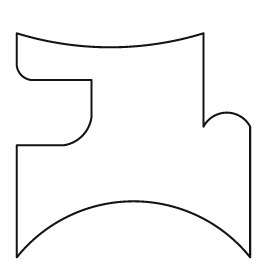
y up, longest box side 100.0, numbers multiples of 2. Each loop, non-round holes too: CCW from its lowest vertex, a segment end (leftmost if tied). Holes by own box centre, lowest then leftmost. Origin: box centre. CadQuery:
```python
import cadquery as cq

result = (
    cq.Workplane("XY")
    .moveTo(-50.0, -48.0)
    .threePointArc((0.0, -24.0), (50.0, -48.0))
    .lineTo(50.0, 8.0)
    .threePointArc((40.0, 14.0), (30.0, 8.0))
    .lineTo(30.0, 48.0)
    .threePointArc((-10.0, 42.0), (-50.0, 48.0))
    .lineTo(-50.0, 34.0)
    .threePointArc((-48.0, 30.0), (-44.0, 28.0))
    .lineTo(-18.0, 28.0)
    .lineTo(-18.0, 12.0)
    .threePointArc((-22.0, 4.0), (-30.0, 0.0))
    .lineTo(-50.0, 0.0)
    .close()
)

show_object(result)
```